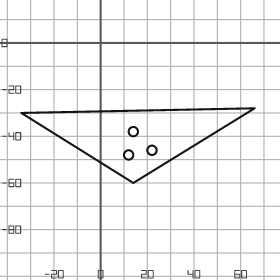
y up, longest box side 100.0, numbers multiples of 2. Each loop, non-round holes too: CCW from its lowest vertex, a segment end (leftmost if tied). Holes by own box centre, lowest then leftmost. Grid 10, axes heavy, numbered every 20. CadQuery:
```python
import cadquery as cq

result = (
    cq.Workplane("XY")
    .moveTo(14.0, -60.0)
    .lineTo(66.0, -28.0)
    .lineTo(-34.0, -30.0)
    .close()
    .moveTo(12.0, -48.0)
    .circle(2.0)
    .moveTo(22.0, -46.0)
    .circle(2.0)
    .moveTo(14.0, -38.0)
    .circle(2.0)
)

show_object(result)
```